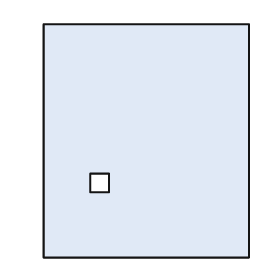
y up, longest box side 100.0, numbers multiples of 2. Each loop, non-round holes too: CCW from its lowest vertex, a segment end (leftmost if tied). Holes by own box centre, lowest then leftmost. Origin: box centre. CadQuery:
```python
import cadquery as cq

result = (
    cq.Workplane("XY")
    .moveTo(-44.0, -50.0)
    .lineTo(44.0, -50.0)
    .lineTo(44.0, 50.0)
    .lineTo(-44.0, 50.0)
    .close()
    .moveTo(-24.0, -22.0)
    .lineTo(-16.0, -22.0)
    .lineTo(-16.0, -14.0)
    .lineTo(-24.0, -14.0)
    .close()
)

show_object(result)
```